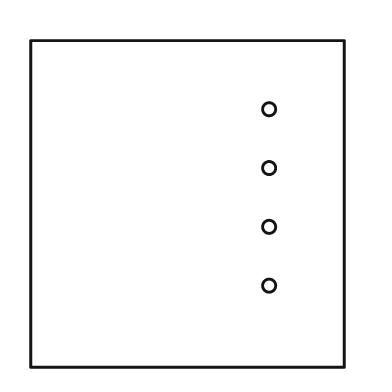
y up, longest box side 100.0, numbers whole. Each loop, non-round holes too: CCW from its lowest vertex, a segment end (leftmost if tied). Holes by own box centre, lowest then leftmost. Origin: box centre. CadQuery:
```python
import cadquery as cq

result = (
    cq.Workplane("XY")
    .moveTo(-48.0, -50.0)
    .lineTo(48.0, -50.0)
    .lineTo(48.0, 50.0)
    .lineTo(-48.0, 50.0)
    .close()
    .moveTo(25.0, -25.0)
    .circle(2.0)
    .moveTo(25.0, -7.0)
    .circle(2.0)
    .moveTo(25.0, 11.0)
    .circle(2.0)
    .moveTo(25.0, 29.0)
    .circle(2.0)
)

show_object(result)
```